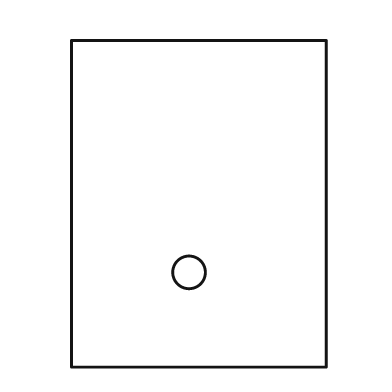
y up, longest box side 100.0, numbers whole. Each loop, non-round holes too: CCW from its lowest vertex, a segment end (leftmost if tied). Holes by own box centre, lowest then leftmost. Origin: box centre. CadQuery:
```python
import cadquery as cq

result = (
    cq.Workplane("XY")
    .moveTo(-39.0, -50.0)
    .lineTo(39.0, -50.0)
    .lineTo(39.0, 50.0)
    .lineTo(-39.0, 50.0)
    .close()
    .moveTo(-3.0, -21.0)
    .circle(5.0)
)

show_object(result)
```